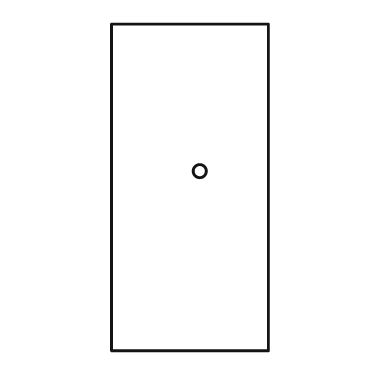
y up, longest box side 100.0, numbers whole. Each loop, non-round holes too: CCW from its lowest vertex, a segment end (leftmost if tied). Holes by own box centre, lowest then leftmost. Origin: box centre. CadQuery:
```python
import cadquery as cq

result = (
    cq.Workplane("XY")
    .moveTo(-24.0, -50.0)
    .lineTo(24.0, -50.0)
    .lineTo(24.0, 50.0)
    .lineTo(-24.0, 50.0)
    .close()
    .moveTo(3.0, 5.0)
    .circle(2.0)
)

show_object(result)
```